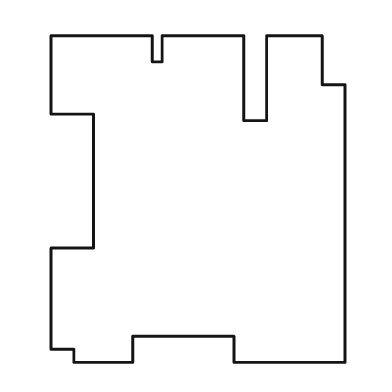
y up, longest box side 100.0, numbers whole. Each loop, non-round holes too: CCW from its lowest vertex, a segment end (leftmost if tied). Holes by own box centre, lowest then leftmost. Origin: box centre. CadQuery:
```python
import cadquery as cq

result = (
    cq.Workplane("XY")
    .moveTo(-38.0, -50.0)
    .lineTo(-20.0, -50.0)
    .lineTo(-20.0, -42.0)
    .lineTo(11.0, -42.0)
    .lineTo(11.0, -50.0)
    .lineTo(45.0, -50.0)
    .lineTo(45.0, 35.0)
    .lineTo(38.0, 35.0)
    .lineTo(38.0, 50.0)
    .lineTo(21.0, 50.0)
    .lineTo(21.0, 24.0)
    .lineTo(14.0, 24.0)
    .lineTo(14.0, 50.0)
    .lineTo(-11.0, 50.0)
    .lineTo(-11.0, 42.0)
    .lineTo(-14.0, 42.0)
    .lineTo(-14.0, 50.0)
    .lineTo(-45.0, 50.0)
    .lineTo(-45.0, 26.0)
    .lineTo(-32.0, 26.0)
    .lineTo(-32.0, -15.0)
    .lineTo(-45.0, -15.0)
    .lineTo(-45.0, -46.0)
    .lineTo(-38.0, -46.0)
    .close()
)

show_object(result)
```